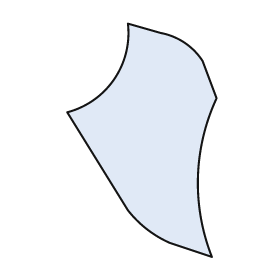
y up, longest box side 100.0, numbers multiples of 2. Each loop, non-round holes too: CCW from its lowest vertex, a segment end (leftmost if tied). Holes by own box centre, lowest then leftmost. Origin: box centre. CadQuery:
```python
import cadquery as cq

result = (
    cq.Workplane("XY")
    .moveTo(30.0, -50.0)
    .threePointArc((24.0, -16.0), (32.0, 18.0))
    .lineTo(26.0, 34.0)
    .threePointArc((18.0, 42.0), (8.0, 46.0))
    .lineTo(-6.0, 50.0)
    .threePointArc((-12.0, 26.0), (-32.0, 12.0))
    .lineTo(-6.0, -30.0)
    .threePointArc((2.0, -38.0), (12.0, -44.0))
    .close()
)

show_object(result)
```